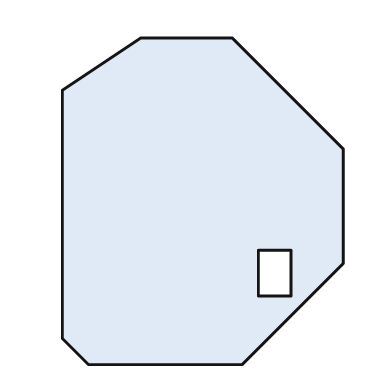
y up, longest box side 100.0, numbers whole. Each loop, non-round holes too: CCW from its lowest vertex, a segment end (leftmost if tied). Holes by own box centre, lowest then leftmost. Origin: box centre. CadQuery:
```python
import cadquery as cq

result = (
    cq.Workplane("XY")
    .moveTo(-35.0, -50.0)
    .lineTo(12.0, -50.0)
    .lineTo(43.0, -19.0)
    .lineTo(43.0, 16.0)
    .lineTo(9.0, 50.0)
    .lineTo(-19.0, 50.0)
    .lineTo(-43.0, 34.0)
    .lineTo(-43.0, -42.0)
    .close()
    .moveTo(17.0, -29.0)
    .lineTo(27.0, -29.0)
    .lineTo(27.0, -15.0)
    .lineTo(17.0, -15.0)
    .close()
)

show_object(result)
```